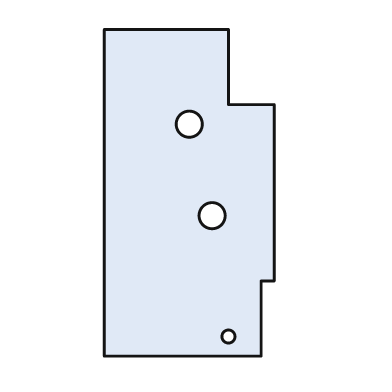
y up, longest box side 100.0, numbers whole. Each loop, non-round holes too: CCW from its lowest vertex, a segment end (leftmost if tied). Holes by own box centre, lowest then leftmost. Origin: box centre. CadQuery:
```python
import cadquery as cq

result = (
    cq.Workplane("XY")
    .moveTo(-26.0, -50.0)
    .lineTo(22.0, -50.0)
    .lineTo(22.0, -27.0)
    .lineTo(26.0, -27.0)
    .lineTo(26.0, 27.0)
    .lineTo(12.0, 27.0)
    .lineTo(12.0, 50.0)
    .lineTo(-26.0, 50.0)
    .close()
    .moveTo(12.0, -44.0)
    .circle(2.0)
    .moveTo(7.0, -7.0)
    .circle(4.0)
    .moveTo(0.0, 21.0)
    .circle(4.0)
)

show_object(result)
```